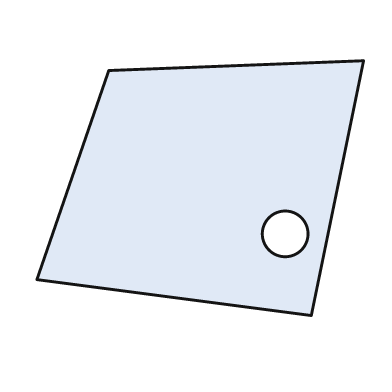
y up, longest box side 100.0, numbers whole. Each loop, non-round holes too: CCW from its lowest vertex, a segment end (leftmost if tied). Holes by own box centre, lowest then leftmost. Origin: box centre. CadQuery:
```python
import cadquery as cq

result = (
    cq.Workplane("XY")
    .moveTo(34.0, -39.0)
    .lineTo(50.0, 39.0)
    .lineTo(-28.0, 36.0)
    .lineTo(-50.0, -28.0)
    .close()
    .moveTo(26.0, -14.0)
    .circle(7.0)
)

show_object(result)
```